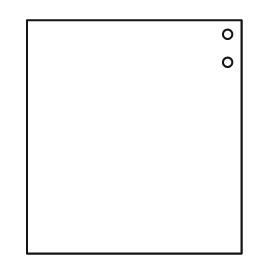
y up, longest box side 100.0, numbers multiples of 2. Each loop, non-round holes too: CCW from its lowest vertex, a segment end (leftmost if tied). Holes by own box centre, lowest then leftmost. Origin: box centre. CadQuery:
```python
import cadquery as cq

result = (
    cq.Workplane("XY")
    .moveTo(-46.0, -50.0)
    .lineTo(46.0, -50.0)
    .lineTo(46.0, 50.0)
    .lineTo(-46.0, 50.0)
    .close()
    .moveTo(40.0, 32.0)
    .circle(2.0)
    .moveTo(40.0, 44.0)
    .circle(2.0)
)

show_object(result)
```